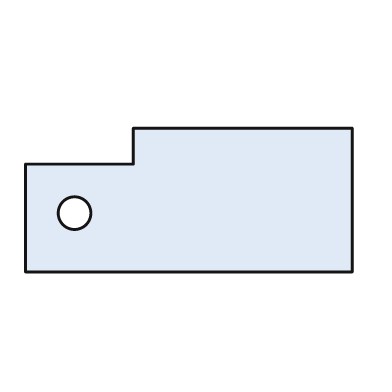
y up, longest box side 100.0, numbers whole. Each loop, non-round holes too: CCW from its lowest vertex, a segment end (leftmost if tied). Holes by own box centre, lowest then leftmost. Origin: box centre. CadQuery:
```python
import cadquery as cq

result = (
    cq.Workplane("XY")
    .moveTo(-50.0, -22.0)
    .lineTo(50.0, -22.0)
    .lineTo(50.0, 22.0)
    .lineTo(-17.0, 22.0)
    .lineTo(-17.0, 11.0)
    .lineTo(-50.0, 11.0)
    .close()
    .moveTo(-35.0, -4.0)
    .circle(5.0)
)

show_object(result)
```